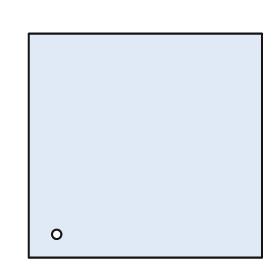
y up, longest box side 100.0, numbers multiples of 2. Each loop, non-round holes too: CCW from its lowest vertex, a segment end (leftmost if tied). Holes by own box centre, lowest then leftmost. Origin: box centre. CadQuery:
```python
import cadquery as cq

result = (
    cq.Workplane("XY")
    .moveTo(-50.0, -48.0)
    .lineTo(50.0, -48.0)
    .lineTo(50.0, 48.0)
    .lineTo(-50.0, 48.0)
    .close()
    .moveTo(-38.0, -38.0)
    .circle(2.0)
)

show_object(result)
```